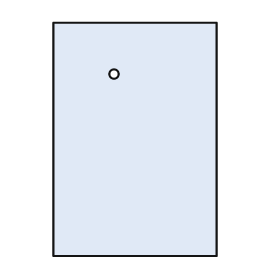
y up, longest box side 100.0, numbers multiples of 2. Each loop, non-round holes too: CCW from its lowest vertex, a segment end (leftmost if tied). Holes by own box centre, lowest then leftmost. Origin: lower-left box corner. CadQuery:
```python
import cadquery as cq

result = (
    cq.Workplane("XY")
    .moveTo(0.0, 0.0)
    .lineTo(70.0, 0.0)
    .lineTo(70.0, 100.0)
    .lineTo(0.0, 100.0)
    .close()
    .moveTo(26.0, 78.0)
    .circle(2.0)
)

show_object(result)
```